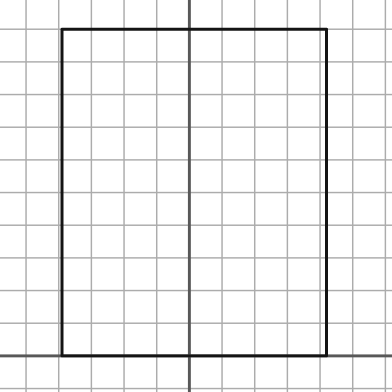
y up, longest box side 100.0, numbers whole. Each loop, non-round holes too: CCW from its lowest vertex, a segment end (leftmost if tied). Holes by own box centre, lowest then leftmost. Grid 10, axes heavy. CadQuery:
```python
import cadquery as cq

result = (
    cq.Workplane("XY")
    .moveTo(-39.0, 0.0)
    .lineTo(42.0, 0.0)
    .lineTo(42.0, 100.0)
    .lineTo(-39.0, 100.0)
    .close()
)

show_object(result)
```